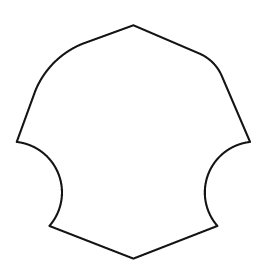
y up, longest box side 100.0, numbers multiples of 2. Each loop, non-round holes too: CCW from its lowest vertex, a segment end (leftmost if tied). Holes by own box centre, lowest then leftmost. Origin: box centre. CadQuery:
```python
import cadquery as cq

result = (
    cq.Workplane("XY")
    .moveTo(0.0, -50.0)
    .lineTo(36.0, -36.0)
    .threePointArc((32.0, -14.0), (50.0, 0.0))
    .lineTo(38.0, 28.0)
    .threePointArc((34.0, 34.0), (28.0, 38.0))
    .lineTo(0.0, 50.0)
    .lineTo(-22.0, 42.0)
    .threePointArc((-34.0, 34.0), (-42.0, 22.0))
    .lineTo(-50.0, 0.0)
    .threePointArc((-32.0, -14.0), (-36.0, -36.0))
    .close()
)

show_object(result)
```